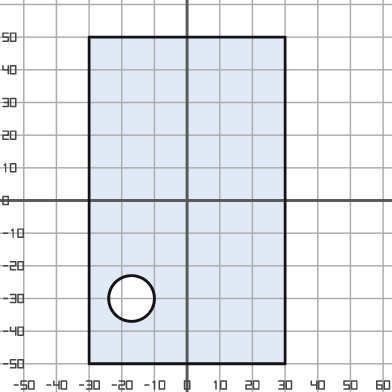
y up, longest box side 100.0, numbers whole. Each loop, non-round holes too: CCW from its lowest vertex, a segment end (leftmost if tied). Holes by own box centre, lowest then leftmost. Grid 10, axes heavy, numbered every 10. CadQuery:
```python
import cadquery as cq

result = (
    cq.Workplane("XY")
    .moveTo(-30.0, -50.0)
    .lineTo(30.0, -50.0)
    .lineTo(30.0, 50.0)
    .lineTo(-30.0, 50.0)
    .close()
    .moveTo(-17.0, -30.0)
    .circle(7.0)
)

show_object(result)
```